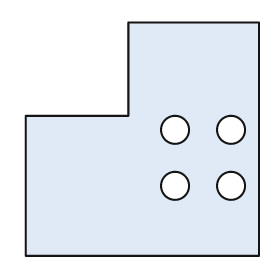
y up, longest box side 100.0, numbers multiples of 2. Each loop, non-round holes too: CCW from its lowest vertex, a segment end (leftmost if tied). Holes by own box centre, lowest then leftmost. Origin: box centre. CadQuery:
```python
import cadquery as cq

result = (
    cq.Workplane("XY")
    .moveTo(-50.0, -50.0)
    .lineTo(50.0, -50.0)
    .lineTo(50.0, 50.0)
    .lineTo(-6.0, 50.0)
    .lineTo(-6.0, 10.0)
    .lineTo(-50.0, 10.0)
    .close()
    .moveTo(14.0, -20.0)
    .circle(6.0)
    .moveTo(38.0, -20.0)
    .circle(6.0)
    .moveTo(14.0, 4.0)
    .circle(6.0)
    .moveTo(38.0, 4.0)
    .circle(6.0)
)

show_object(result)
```